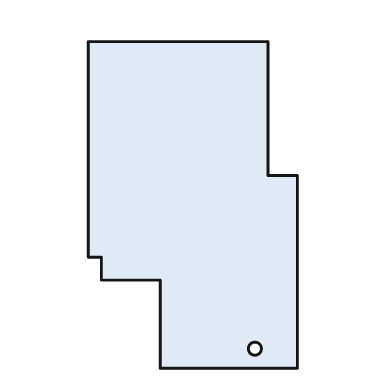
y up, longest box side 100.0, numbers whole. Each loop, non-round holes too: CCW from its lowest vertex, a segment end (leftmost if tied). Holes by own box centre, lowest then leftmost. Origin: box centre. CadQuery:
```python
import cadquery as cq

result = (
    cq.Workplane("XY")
    .moveTo(-10.0, -50.0)
    .lineTo(32.0, -50.0)
    .lineTo(32.0, 9.0)
    .lineTo(23.0, 9.0)
    .lineTo(23.0, 50.0)
    .lineTo(-32.0, 50.0)
    .lineTo(-32.0, -16.0)
    .lineTo(-28.0, -16.0)
    .lineTo(-28.0, -23.0)
    .lineTo(-10.0, -23.0)
    .close()
    .moveTo(19.0, -44.0)
    .circle(2.0)
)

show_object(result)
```